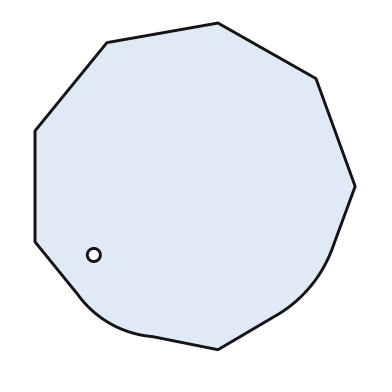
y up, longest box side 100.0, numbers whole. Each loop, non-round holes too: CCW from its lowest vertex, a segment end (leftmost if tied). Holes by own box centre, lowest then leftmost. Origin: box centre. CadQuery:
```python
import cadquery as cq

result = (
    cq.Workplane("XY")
    .moveTo(7.0, -50.0)
    .lineTo(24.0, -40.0)
    .threePointArc((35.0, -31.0), (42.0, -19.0))
    .lineTo(49.0, 0.0)
    .lineTo(37.0, 33.0)
    .lineTo(7.0, 50.0)
    .lineTo(-27.0, 44.0)
    .lineTo(-49.0, 17.0)
    .lineTo(-49.0, -17.0)
    .lineTo(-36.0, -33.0)
    .threePointArc((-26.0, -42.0), (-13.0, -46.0))
    .close()
    .moveTo(-31.0, -21.0)
    .circle(2.0)
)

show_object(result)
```